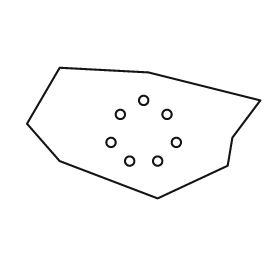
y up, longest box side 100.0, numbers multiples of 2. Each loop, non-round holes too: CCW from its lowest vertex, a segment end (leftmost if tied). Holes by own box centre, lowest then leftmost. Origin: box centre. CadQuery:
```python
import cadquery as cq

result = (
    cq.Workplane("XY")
    .moveTo(6.0, -28.0)
    .lineTo(36.0, -14.0)
    .lineTo(38.0, -2.0)
    .lineTo(50.0, 14.0)
    .lineTo(2.0, 26.0)
    .lineTo(-36.0, 28.0)
    .lineTo(-50.0, 4.0)
    .lineTo(-36.0, -12.0)
    .close()
    .moveTo(-6.0, -12.0)
    .circle(2.0)
    .moveTo(6.0, -12.0)
    .circle(2.0)
    .moveTo(-14.0, -4.0)
    .circle(2.0)
    .moveTo(14.0, -4.0)
    .circle(2.0)
    .moveTo(-10.0, 8.0)
    .circle(2.0)
    .moveTo(10.0, 8.0)
    .circle(2.0)
    .moveTo(0.0, 14.0)
    .circle(2.0)
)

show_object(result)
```